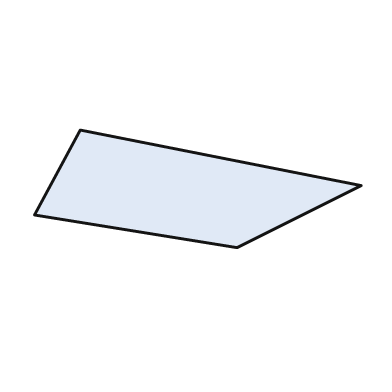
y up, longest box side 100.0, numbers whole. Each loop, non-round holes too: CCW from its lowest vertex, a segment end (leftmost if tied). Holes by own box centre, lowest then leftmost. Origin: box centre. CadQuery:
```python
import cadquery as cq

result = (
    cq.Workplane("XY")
    .moveTo(12.0, -18.0)
    .lineTo(50.0, 1.0)
    .lineTo(-36.0, 18.0)
    .lineTo(-50.0, -8.0)
    .close()
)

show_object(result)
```